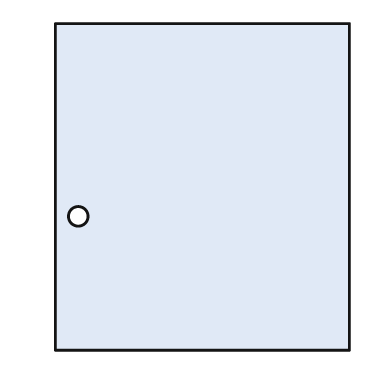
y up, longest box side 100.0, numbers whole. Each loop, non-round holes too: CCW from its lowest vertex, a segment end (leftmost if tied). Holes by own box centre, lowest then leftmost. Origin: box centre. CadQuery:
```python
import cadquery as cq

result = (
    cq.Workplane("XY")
    .moveTo(-45.0, -50.0)
    .lineTo(45.0, -50.0)
    .lineTo(45.0, 50.0)
    .lineTo(-45.0, 50.0)
    .close()
    .moveTo(-38.0, -9.0)
    .circle(3.0)
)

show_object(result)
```